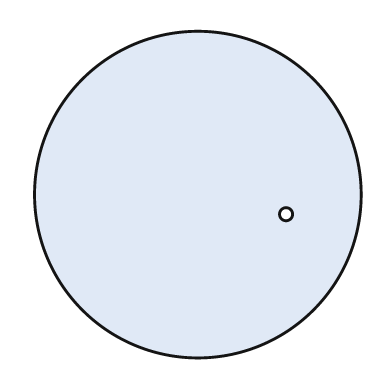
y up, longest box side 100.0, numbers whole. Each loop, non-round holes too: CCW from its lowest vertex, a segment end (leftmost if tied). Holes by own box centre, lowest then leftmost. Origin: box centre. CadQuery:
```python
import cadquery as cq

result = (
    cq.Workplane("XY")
    .moveTo(0.0, 0.0)
    .circle(50.0)
    .moveTo(27.0, -6.0)
    .circle(2.0)
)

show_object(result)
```